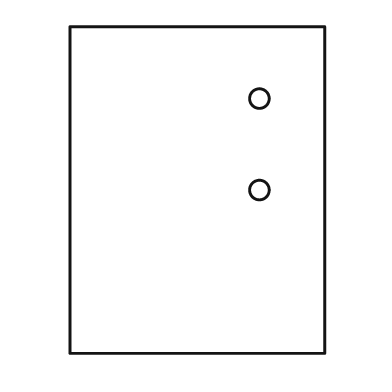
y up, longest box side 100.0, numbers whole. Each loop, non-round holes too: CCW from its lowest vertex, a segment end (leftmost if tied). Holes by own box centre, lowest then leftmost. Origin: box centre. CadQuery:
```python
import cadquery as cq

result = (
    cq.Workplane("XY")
    .moveTo(-39.0, -50.0)
    .lineTo(39.0, -50.0)
    .lineTo(39.0, 50.0)
    .lineTo(-39.0, 50.0)
    .close()
    .moveTo(19.0, 0.0)
    .circle(3.0)
    .moveTo(19.0, 28.0)
    .circle(3.0)
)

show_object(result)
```